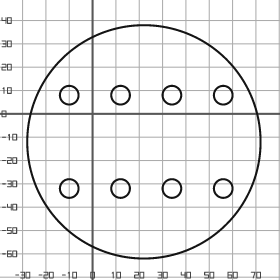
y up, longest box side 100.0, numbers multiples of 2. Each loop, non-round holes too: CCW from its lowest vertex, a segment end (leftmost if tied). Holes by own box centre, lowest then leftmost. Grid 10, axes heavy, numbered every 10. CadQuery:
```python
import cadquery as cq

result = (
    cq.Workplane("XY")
    .moveTo(22.0, -12.0)
    .circle(50.0)
    .moveTo(-10.0, -32.0)
    .circle(4.0)
    .moveTo(12.0, -32.0)
    .circle(4.0)
    .moveTo(34.0, -32.0)
    .circle(4.0)
    .moveTo(56.0, -32.0)
    .circle(4.0)
    .moveTo(-10.0, 8.0)
    .circle(4.0)
    .moveTo(12.0, 8.0)
    .circle(4.0)
    .moveTo(34.0, 8.0)
    .circle(4.0)
    .moveTo(56.0, 8.0)
    .circle(4.0)
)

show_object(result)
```